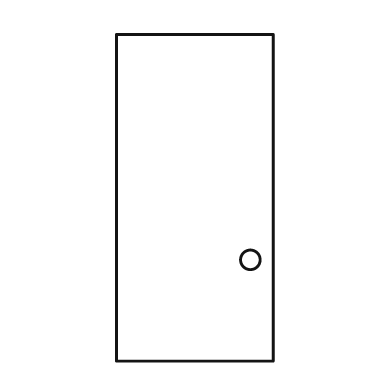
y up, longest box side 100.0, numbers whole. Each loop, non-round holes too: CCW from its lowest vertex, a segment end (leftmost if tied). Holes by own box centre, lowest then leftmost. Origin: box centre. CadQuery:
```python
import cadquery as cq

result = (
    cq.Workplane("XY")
    .moveTo(-24.0, -50.0)
    .lineTo(24.0, -50.0)
    .lineTo(24.0, 50.0)
    .lineTo(-24.0, 50.0)
    .close()
    .moveTo(17.0, -19.0)
    .circle(3.0)
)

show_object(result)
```